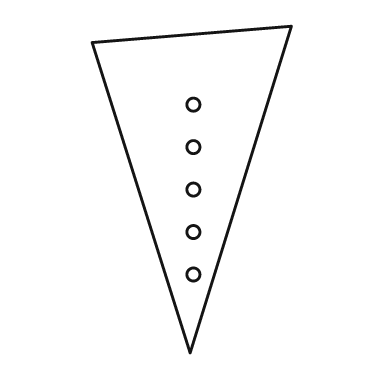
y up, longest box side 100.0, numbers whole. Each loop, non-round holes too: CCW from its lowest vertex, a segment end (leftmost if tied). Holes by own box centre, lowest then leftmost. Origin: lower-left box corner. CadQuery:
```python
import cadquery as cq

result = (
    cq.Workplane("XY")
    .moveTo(30.0, 0.0)
    .lineTo(61.0, 100.0)
    .lineTo(0.0, 95.0)
    .close()
    .moveTo(31.0, 24.0)
    .circle(2.0)
    .moveTo(31.0, 37.0)
    .circle(2.0)
    .moveTo(31.0, 50.0)
    .circle(2.0)
    .moveTo(31.0, 63.0)
    .circle(2.0)
    .moveTo(31.0, 76.0)
    .circle(2.0)
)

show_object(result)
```